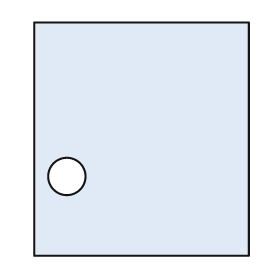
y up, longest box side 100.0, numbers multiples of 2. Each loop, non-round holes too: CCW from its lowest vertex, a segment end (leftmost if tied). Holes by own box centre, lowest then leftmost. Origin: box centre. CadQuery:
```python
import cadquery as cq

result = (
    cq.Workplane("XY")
    .moveTo(-46.0, -50.0)
    .lineTo(46.0, -50.0)
    .lineTo(46.0, 50.0)
    .lineTo(-46.0, 50.0)
    .close()
    .moveTo(-32.0, -16.0)
    .circle(8.0)
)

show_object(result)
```